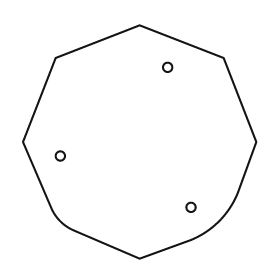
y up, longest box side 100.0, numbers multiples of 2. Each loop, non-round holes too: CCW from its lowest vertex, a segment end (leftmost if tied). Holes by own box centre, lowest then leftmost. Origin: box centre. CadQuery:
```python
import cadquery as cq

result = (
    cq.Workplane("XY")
    .moveTo(0.0, -50.0)
    .lineTo(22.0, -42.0)
    .threePointArc((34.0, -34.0), (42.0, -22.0))
    .lineTo(50.0, 0.0)
    .lineTo(36.0, 36.0)
    .lineTo(0.0, 50.0)
    .lineTo(-36.0, 36.0)
    .lineTo(-50.0, 0.0)
    .lineTo(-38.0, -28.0)
    .threePointArc((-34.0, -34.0), (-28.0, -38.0))
    .close()
    .moveTo(22.0, -28.0)
    .circle(2.0)
    .moveTo(-34.0, -6.0)
    .circle(2.0)
    .moveTo(12.0, 32.0)
    .circle(2.0)
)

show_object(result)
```